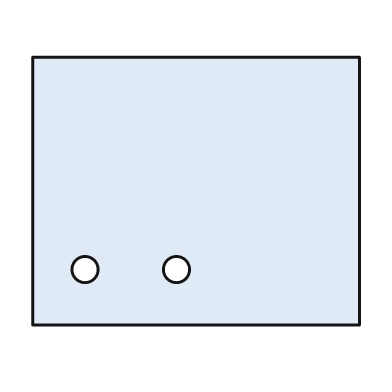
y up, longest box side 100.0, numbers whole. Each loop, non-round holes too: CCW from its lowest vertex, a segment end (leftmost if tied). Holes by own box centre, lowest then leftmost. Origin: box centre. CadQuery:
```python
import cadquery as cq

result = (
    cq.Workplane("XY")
    .moveTo(-50.0, -41.0)
    .lineTo(50.0, -41.0)
    .lineTo(50.0, 41.0)
    .lineTo(-50.0, 41.0)
    .close()
    .moveTo(-34.0, -24.0)
    .circle(4.0)
    .moveTo(-6.0, -24.0)
    .circle(4.0)
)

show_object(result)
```